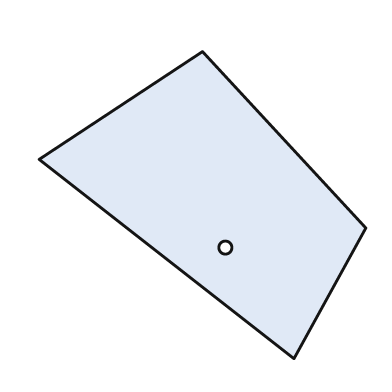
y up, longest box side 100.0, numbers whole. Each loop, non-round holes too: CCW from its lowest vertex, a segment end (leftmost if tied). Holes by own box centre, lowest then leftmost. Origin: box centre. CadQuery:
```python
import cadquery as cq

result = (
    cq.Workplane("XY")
    .moveTo(28.0, -47.0)
    .lineTo(50.0, -7.0)
    .lineTo(0.0, 47.0)
    .lineTo(-50.0, 14.0)
    .close()
    .moveTo(7.0, -13.0)
    .circle(2.0)
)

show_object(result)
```